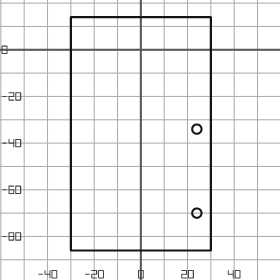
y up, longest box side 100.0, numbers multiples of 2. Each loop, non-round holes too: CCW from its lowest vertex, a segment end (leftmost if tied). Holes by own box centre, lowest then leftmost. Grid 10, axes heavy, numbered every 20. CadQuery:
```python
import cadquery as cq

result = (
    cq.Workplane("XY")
    .moveTo(-30.0, -86.0)
    .lineTo(30.0, -86.0)
    .lineTo(30.0, 14.0)
    .lineTo(-30.0, 14.0)
    .close()
    .moveTo(24.0, -70.0)
    .circle(2.0)
    .moveTo(24.0, -34.0)
    .circle(2.0)
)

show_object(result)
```